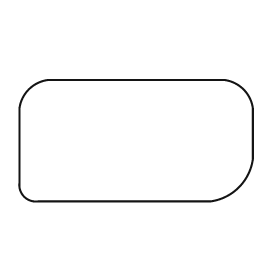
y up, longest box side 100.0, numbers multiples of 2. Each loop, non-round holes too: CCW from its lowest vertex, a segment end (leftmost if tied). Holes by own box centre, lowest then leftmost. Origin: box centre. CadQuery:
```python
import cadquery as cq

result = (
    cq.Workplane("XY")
    .moveTo(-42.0, -26.0)
    .lineTo(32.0, -26.0)
    .threePointArc((44.0, -20.0), (50.0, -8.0))
    .lineTo(50.0, 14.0)
    .threePointArc((46.0, 22.0), (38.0, 26.0))
    .lineTo(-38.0, 26.0)
    .threePointArc((-46.0, 22.0), (-50.0, 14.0))
    .lineTo(-50.0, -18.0)
    .threePointArc((-48.0, -24.0), (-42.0, -26.0))
    .close()
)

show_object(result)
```